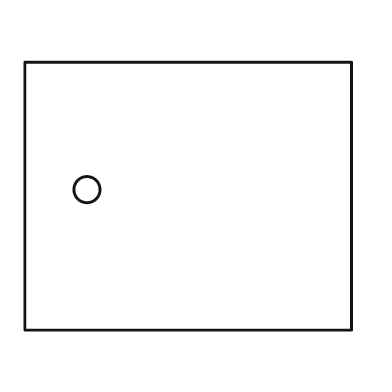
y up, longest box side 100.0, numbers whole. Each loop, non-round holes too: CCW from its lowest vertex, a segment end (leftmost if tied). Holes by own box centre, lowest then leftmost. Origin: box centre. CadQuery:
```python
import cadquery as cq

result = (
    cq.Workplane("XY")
    .moveTo(-50.0, -41.0)
    .lineTo(50.0, -41.0)
    .lineTo(50.0, 41.0)
    .lineTo(-50.0, 41.0)
    .close()
    .moveTo(-31.0, 2.0)
    .circle(4.0)
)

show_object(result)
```